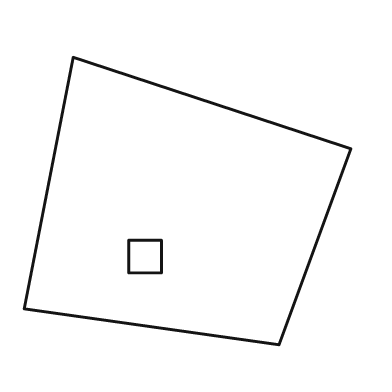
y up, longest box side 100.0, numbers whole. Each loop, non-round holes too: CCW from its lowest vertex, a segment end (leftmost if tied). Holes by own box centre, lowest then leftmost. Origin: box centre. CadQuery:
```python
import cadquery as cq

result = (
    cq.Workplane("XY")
    .moveTo(28.0, -44.0)
    .lineTo(50.0, 16.0)
    .lineTo(-35.0, 44.0)
    .lineTo(-50.0, -33.0)
    .close()
    .moveTo(-18.0, -22.0)
    .lineTo(-8.0, -22.0)
    .lineTo(-8.0, -12.0)
    .lineTo(-18.0, -12.0)
    .close()
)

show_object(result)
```